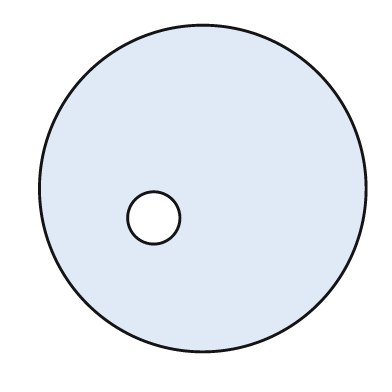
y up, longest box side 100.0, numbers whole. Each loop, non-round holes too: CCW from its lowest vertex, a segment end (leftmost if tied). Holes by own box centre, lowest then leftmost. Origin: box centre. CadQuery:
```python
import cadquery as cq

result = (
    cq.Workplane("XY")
    .moveTo(0.0, 0.0)
    .circle(50.0)
    .moveTo(-15.0, -9.0)
    .circle(8.0)
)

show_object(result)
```